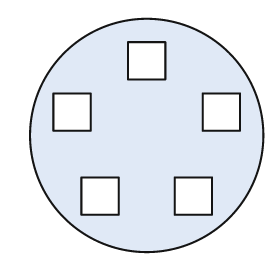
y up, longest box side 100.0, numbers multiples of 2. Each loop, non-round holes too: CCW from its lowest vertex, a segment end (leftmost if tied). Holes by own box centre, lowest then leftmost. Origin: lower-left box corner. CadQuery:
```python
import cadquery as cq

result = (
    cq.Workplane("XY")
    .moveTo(50.0, 50.0)
    .circle(50.0)
    .moveTo(22.0, 16.0)
    .lineTo(38.0, 16.0)
    .lineTo(38.0, 32.0)
    .lineTo(22.0, 32.0)
    .close()
    .moveTo(62.0, 16.0)
    .lineTo(78.0, 16.0)
    .lineTo(78.0, 32.0)
    .lineTo(62.0, 32.0)
    .close()
    .moveTo(10.0, 52.0)
    .lineTo(26.0, 52.0)
    .lineTo(26.0, 68.0)
    .lineTo(10.0, 68.0)
    .close()
    .moveTo(74.0, 52.0)
    .lineTo(90.0, 52.0)
    .lineTo(90.0, 68.0)
    .lineTo(74.0, 68.0)
    .close()
    .moveTo(42.0, 74.0)
    .lineTo(58.0, 74.0)
    .lineTo(58.0, 90.0)
    .lineTo(42.0, 90.0)
    .close()
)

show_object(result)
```